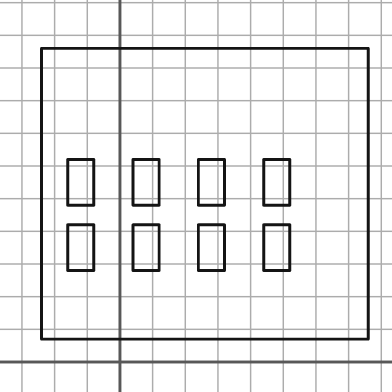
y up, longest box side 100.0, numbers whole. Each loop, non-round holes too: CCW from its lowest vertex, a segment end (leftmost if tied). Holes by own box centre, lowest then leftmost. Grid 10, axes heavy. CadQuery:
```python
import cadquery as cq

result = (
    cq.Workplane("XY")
    .moveTo(-24.0, 7.0)
    .lineTo(76.0, 7.0)
    .lineTo(76.0, 96.0)
    .lineTo(-24.0, 96.0)
    .close()
    .moveTo(-16.0, 28.0)
    .lineTo(-8.0, 28.0)
    .lineTo(-8.0, 42.0)
    .lineTo(-16.0, 42.0)
    .close()
    .moveTo(4.0, 28.0)
    .lineTo(12.0, 28.0)
    .lineTo(12.0, 42.0)
    .lineTo(4.0, 42.0)
    .close()
    .moveTo(24.0, 28.0)
    .lineTo(32.0, 28.0)
    .lineTo(32.0, 42.0)
    .lineTo(24.0, 42.0)
    .close()
    .moveTo(44.0, 28.0)
    .lineTo(52.0, 28.0)
    .lineTo(52.0, 42.0)
    .lineTo(44.0, 42.0)
    .close()
    .moveTo(-16.0, 48.0)
    .lineTo(-8.0, 48.0)
    .lineTo(-8.0, 62.0)
    .lineTo(-16.0, 62.0)
    .close()
    .moveTo(4.0, 48.0)
    .lineTo(12.0, 48.0)
    .lineTo(12.0, 62.0)
    .lineTo(4.0, 62.0)
    .close()
    .moveTo(24.0, 48.0)
    .lineTo(32.0, 48.0)
    .lineTo(32.0, 62.0)
    .lineTo(24.0, 62.0)
    .close()
    .moveTo(44.0, 48.0)
    .lineTo(52.0, 48.0)
    .lineTo(52.0, 62.0)
    .lineTo(44.0, 62.0)
    .close()
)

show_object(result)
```